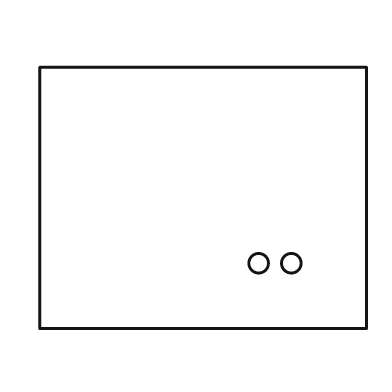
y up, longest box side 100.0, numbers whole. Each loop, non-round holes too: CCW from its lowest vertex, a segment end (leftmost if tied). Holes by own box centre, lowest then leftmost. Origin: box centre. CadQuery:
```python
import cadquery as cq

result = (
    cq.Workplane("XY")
    .moveTo(-50.0, -40.0)
    .lineTo(50.0, -40.0)
    .lineTo(50.0, 40.0)
    .lineTo(-50.0, 40.0)
    .close()
    .moveTo(17.0, -20.0)
    .circle(3.0)
    .moveTo(27.0, -20.0)
    .circle(3.0)
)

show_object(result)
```